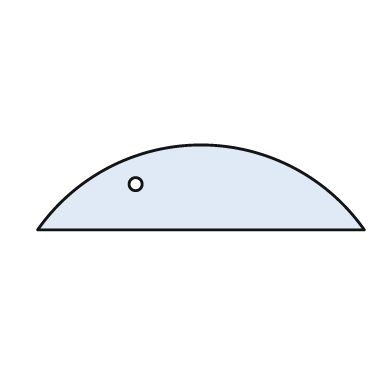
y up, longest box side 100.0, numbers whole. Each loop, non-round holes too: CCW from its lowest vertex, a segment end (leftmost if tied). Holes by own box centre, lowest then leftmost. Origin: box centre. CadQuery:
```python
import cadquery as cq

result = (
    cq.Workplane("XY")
    .moveTo(-50.0, -13.0)
    .lineTo(50.0, -13.0)
    .threePointArc((0.0, 13.0), (-50.0, -13.0))
    .close()
    .moveTo(-20.0, 1.0)
    .circle(2.0)
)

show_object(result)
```